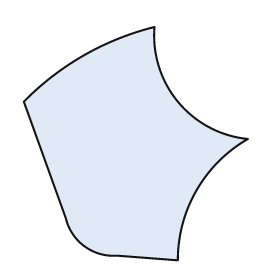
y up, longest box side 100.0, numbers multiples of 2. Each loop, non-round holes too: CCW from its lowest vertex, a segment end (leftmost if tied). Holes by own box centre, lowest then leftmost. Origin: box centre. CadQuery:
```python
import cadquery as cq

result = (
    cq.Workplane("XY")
    .moveTo(18.0, -50.0)
    .threePointArc((26.0, -20.0), (48.0, 2.0))
    .threePointArc((18.0, 18.0), (8.0, 50.0))
    .threePointArc((-22.0, 38.0), (-48.0, 18.0))
    .lineTo(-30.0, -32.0)
    .threePointArc((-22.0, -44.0), (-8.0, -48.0))
    .close()
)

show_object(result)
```